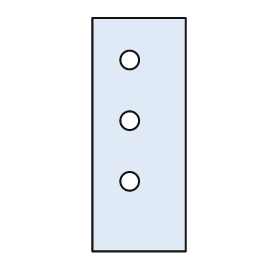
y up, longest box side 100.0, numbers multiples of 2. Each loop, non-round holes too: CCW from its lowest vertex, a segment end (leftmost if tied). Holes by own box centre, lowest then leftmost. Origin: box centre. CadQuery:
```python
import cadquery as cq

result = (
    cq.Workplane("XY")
    .moveTo(-20.0, -50.0)
    .lineTo(20.0, -50.0)
    .lineTo(20.0, 50.0)
    .lineTo(-20.0, 50.0)
    .close()
    .moveTo(-4.0, -20.0)
    .circle(4.0)
    .moveTo(-4.0, 6.0)
    .circle(4.0)
    .moveTo(-4.0, 32.0)
    .circle(4.0)
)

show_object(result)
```